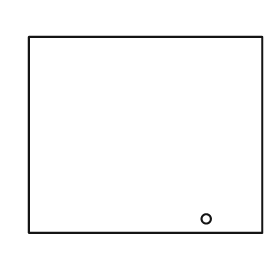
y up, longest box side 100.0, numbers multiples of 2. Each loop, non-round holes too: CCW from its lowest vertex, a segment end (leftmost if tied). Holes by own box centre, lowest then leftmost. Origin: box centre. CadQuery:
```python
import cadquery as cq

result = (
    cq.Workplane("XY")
    .moveTo(-50.0, -42.0)
    .lineTo(50.0, -42.0)
    .lineTo(50.0, 42.0)
    .lineTo(-50.0, 42.0)
    .close()
    .moveTo(26.0, -36.0)
    .circle(2.0)
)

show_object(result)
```